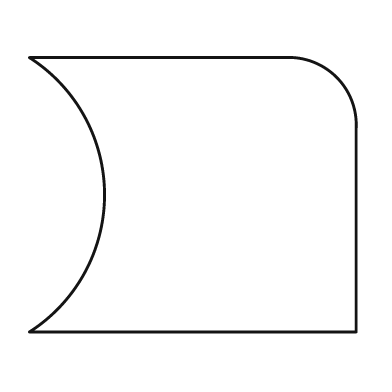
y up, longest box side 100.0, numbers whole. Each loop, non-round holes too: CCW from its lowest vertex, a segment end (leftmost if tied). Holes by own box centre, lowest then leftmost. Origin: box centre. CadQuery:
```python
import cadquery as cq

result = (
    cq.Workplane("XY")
    .moveTo(-50.0, -42.0)
    .lineTo(50.0, -42.0)
    .lineTo(50.0, 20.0)
    .threePointArc((44.0, 36.0), (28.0, 42.0))
    .lineTo(-50.0, 42.0)
    .threePointArc((-27.0, 0.0), (-50.0, -42.0))
    .close()
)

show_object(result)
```